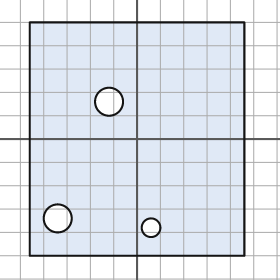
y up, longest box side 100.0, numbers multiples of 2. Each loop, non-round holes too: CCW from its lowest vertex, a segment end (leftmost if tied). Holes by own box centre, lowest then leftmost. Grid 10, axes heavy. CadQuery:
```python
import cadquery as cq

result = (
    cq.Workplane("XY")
    .moveTo(-46.0, -50.0)
    .lineTo(46.0, -50.0)
    .lineTo(46.0, 50.0)
    .lineTo(-46.0, 50.0)
    .close()
    .moveTo(6.0, -38.0)
    .circle(4.0)
    .moveTo(-34.0, -34.0)
    .circle(6.0)
    .moveTo(-12.0, 16.0)
    .circle(6.0)
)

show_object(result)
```